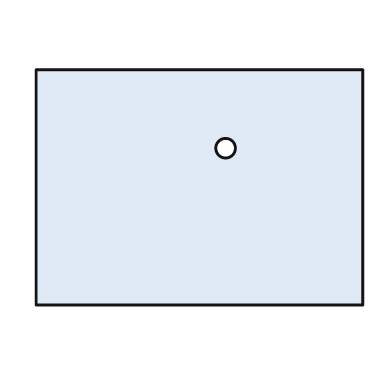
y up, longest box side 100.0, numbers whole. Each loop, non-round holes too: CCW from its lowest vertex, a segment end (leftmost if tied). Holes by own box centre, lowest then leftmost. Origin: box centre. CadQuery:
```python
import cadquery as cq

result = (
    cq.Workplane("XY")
    .moveTo(-50.0, -36.0)
    .lineTo(50.0, -36.0)
    .lineTo(50.0, 36.0)
    .lineTo(-50.0, 36.0)
    .close()
    .moveTo(8.0, 12.0)
    .circle(3.0)
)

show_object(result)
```